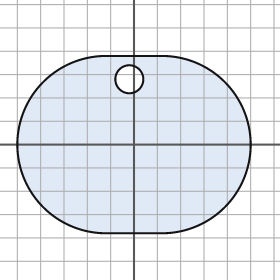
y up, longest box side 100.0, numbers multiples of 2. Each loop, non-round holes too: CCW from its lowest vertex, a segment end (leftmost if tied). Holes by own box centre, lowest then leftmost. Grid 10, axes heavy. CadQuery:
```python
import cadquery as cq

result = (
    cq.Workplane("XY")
    .moveTo(-12.0, -38.0)
    .lineTo(12.0, -38.0)
    .threePointArc((50.0, 0.0), (12.0, 38.0))
    .lineTo(-12.0, 38.0)
    .threePointArc((-50.0, 0.0), (-12.0, -38.0))
    .close()
    .moveTo(-2.0, 28.0)
    .circle(6.0)
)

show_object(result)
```